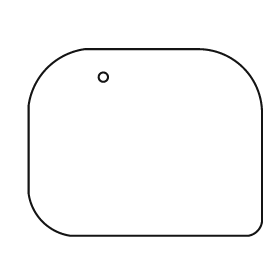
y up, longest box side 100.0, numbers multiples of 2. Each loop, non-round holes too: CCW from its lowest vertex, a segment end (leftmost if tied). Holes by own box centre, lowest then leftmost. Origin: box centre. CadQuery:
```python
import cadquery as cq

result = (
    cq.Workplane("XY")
    .moveTo(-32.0, -40.0)
    .lineTo(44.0, -40.0)
    .threePointArc((48.0, -38.0), (50.0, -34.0))
    .lineTo(50.0, 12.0)
    .threePointArc((42.0, 32.0), (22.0, 40.0))
    .lineTo(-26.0, 40.0)
    .threePointArc((-42.0, 32.0), (-50.0, 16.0))
    .lineTo(-50.0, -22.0)
    .threePointArc((-44.0, -34.0), (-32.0, -40.0))
    .close()
    .moveTo(-18.0, 28.0)
    .circle(2.0)
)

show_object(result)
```